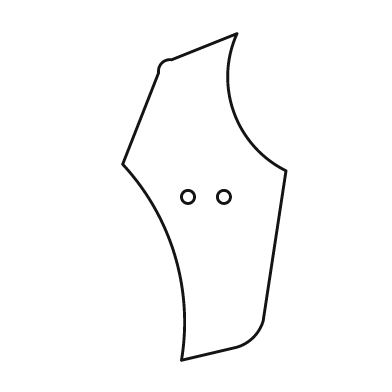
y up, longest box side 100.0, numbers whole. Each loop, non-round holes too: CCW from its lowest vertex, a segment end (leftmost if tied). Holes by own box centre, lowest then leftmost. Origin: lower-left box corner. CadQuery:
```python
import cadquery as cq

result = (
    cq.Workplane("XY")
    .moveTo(18.0, 0.0)
    .lineTo(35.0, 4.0)
    .threePointArc((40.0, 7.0), (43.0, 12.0))
    .lineTo(50.0, 58.0)
    .threePointArc((34.0, 76.0), (35.0, 100.0))
    .lineTo(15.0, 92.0)
    .threePointArc((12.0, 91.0), (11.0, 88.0))
    .lineTo(0.0, 60.0)
    .threePointArc((16.0, 32.0), (18.0, 0.0))
    .close()
    .moveTo(20.0, 50.0)
    .circle(2.0)
    .moveTo(31.0, 50.0)
    .circle(2.0)
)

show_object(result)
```